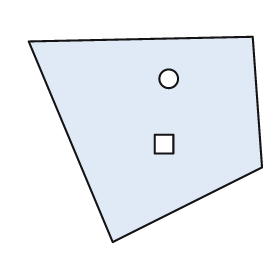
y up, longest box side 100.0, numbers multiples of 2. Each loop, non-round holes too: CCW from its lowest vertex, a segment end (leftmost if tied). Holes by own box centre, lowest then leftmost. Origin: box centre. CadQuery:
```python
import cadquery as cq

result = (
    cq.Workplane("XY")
    .moveTo(-14.0, -44.0)
    .lineTo(50.0, -12.0)
    .lineTo(46.0, 44.0)
    .lineTo(-50.0, 42.0)
    .close()
    .moveTo(4.0, -6.0)
    .lineTo(12.0, -6.0)
    .lineTo(12.0, 2.0)
    .lineTo(4.0, 2.0)
    .close()
    .moveTo(10.0, 26.0)
    .circle(4.0)
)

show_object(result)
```